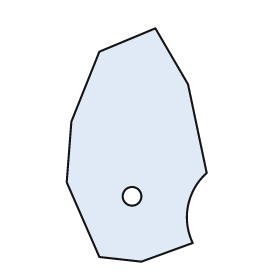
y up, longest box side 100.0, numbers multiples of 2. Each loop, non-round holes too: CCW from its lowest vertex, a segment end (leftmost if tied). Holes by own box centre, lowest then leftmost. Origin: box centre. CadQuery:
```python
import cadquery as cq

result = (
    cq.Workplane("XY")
    .moveTo(2.0, -50.0)
    .lineTo(24.0, -42.0)
    .threePointArc((22.0, -26.0), (30.0, -12.0))
    .lineTo(22.0, 26.0)
    .lineTo(8.0, 50.0)
    .lineTo(-16.0, 40.0)
    .lineTo(-28.0, 10.0)
    .lineTo(-30.0, -16.0)
    .lineTo(-16.0, -48.0)
    .close()
    .moveTo(-2.0, -22.0)
    .circle(4.0)
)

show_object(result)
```